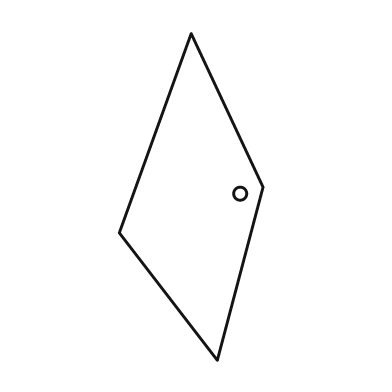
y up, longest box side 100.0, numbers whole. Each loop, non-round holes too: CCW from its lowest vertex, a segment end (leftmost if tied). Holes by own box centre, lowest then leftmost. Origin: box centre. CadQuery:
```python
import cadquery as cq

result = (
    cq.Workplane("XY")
    .moveTo(8.0, -50.0)
    .lineTo(22.0, 3.0)
    .lineTo(0.0, 50.0)
    .lineTo(-22.0, -11.0)
    .close()
    .moveTo(15.0, 1.0)
    .circle(2.0)
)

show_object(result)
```